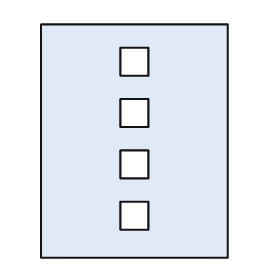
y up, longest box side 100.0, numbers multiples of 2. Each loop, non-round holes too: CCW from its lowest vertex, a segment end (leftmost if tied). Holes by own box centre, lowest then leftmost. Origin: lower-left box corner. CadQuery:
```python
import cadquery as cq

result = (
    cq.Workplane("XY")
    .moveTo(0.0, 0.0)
    .lineTo(80.0, 0.0)
    .lineTo(80.0, 100.0)
    .lineTo(0.0, 100.0)
    .close()
    .moveTo(34.0, 12.0)
    .lineTo(46.0, 12.0)
    .lineTo(46.0, 24.0)
    .lineTo(34.0, 24.0)
    .close()
    .moveTo(34.0, 34.0)
    .lineTo(46.0, 34.0)
    .lineTo(46.0, 46.0)
    .lineTo(34.0, 46.0)
    .close()
    .moveTo(34.0, 56.0)
    .lineTo(46.0, 56.0)
    .lineTo(46.0, 68.0)
    .lineTo(34.0, 68.0)
    .close()
    .moveTo(34.0, 78.0)
    .lineTo(46.0, 78.0)
    .lineTo(46.0, 90.0)
    .lineTo(34.0, 90.0)
    .close()
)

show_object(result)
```